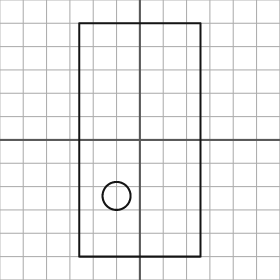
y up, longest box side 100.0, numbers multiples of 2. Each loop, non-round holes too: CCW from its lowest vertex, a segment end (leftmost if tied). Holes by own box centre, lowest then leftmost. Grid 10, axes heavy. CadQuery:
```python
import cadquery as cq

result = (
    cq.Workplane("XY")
    .moveTo(-26.0, -50.0)
    .lineTo(26.0, -50.0)
    .lineTo(26.0, 50.0)
    .lineTo(-26.0, 50.0)
    .close()
    .moveTo(-10.0, -24.0)
    .circle(6.0)
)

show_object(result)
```